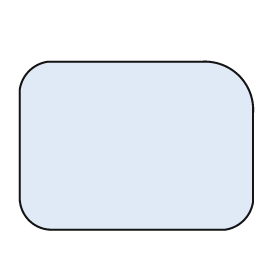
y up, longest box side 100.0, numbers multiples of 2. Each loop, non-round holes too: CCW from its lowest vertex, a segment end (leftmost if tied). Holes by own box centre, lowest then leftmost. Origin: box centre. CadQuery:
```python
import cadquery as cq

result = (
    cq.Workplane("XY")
    .moveTo(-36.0, -36.0)
    .lineTo(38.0, -36.0)
    .threePointArc((46.0, -32.0), (50.0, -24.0))
    .lineTo(50.0, 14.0)
    .threePointArc((44.0, 30.0), (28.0, 36.0))
    .lineTo(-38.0, 36.0)
    .threePointArc((-46.0, 32.0), (-50.0, 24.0))
    .lineTo(-50.0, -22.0)
    .threePointArc((-46.0, -32.0), (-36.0, -36.0))
    .close()
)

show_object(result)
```